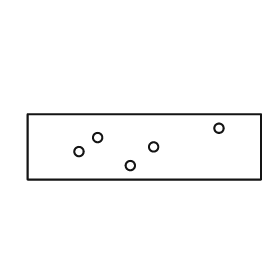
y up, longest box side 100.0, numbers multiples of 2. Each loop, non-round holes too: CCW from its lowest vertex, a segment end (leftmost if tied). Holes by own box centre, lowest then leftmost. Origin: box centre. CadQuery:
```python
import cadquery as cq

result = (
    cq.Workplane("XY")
    .moveTo(-50.0, -14.0)
    .lineTo(50.0, -14.0)
    .lineTo(50.0, 14.0)
    .lineTo(-50.0, 14.0)
    .close()
    .moveTo(-6.0, -8.0)
    .circle(2.0)
    .moveTo(-28.0, -2.0)
    .circle(2.0)
    .moveTo(4.0, 0.0)
    .circle(2.0)
    .moveTo(-20.0, 4.0)
    .circle(2.0)
    .moveTo(32.0, 8.0)
    .circle(2.0)
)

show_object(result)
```